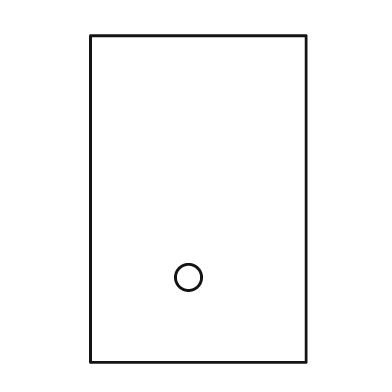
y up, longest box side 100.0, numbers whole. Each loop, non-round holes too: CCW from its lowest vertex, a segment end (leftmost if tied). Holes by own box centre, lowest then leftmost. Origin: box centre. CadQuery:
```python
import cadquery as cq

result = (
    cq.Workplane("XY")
    .moveTo(-33.0, -50.0)
    .lineTo(33.0, -50.0)
    .lineTo(33.0, 50.0)
    .lineTo(-33.0, 50.0)
    .close()
    .moveTo(-3.0, -24.0)
    .circle(4.0)
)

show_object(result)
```